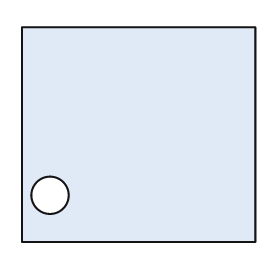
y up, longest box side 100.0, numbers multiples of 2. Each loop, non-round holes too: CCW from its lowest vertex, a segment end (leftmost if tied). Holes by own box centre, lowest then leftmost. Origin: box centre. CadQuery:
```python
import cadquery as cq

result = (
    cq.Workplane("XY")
    .moveTo(-50.0, -46.0)
    .lineTo(50.0, -46.0)
    .lineTo(50.0, 46.0)
    .lineTo(-50.0, 46.0)
    .close()
    .moveTo(-38.0, -26.0)
    .circle(8.0)
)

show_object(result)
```